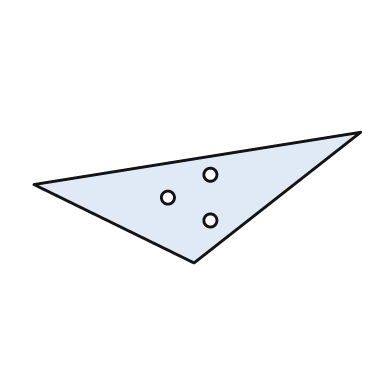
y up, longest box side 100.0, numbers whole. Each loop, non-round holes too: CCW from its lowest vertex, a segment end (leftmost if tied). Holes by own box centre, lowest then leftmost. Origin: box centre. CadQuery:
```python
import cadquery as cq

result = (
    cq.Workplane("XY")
    .moveTo(-1.0, -20.0)
    .lineTo(50.0, 20.0)
    .lineTo(-50.0, 4.0)
    .close()
    .moveTo(4.0, -7.0)
    .circle(2.0)
    .moveTo(-9.0, 0.0)
    .circle(2.0)
    .moveTo(4.0, 7.0)
    .circle(2.0)
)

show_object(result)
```